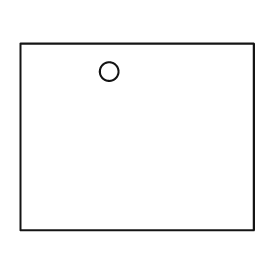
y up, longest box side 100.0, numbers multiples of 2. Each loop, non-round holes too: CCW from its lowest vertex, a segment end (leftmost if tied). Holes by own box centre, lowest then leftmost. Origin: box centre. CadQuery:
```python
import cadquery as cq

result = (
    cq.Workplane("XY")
    .moveTo(-50.0, -40.0)
    .lineTo(50.0, -40.0)
    .lineTo(50.0, 40.0)
    .lineTo(-50.0, 40.0)
    .close()
    .moveTo(-12.0, 28.0)
    .circle(4.0)
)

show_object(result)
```